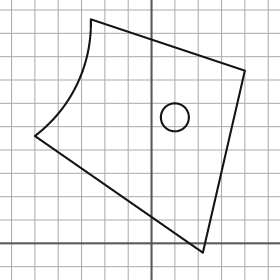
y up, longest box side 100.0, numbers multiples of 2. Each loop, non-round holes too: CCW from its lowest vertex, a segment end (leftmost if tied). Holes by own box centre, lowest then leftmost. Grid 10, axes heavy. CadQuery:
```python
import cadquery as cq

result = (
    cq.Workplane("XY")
    .moveTo(22.0, -4.0)
    .lineTo(40.0, 74.0)
    .lineTo(-26.0, 96.0)
    .threePointArc((-32.0, 68.0), (-50.0, 46.0))
    .close()
    .moveTo(10.0, 54.0)
    .circle(6.0)
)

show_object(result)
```